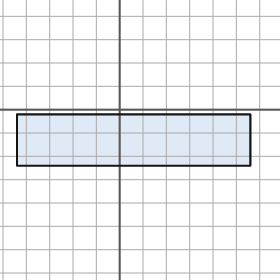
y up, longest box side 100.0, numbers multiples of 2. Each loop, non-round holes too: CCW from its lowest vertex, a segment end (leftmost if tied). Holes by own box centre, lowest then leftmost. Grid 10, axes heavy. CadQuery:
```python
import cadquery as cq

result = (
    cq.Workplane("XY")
    .moveTo(-44.0, -24.0)
    .lineTo(56.0, -24.0)
    .lineTo(56.0, -2.0)
    .lineTo(-44.0, -2.0)
    .close()
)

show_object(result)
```